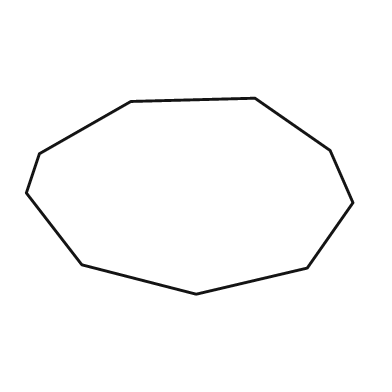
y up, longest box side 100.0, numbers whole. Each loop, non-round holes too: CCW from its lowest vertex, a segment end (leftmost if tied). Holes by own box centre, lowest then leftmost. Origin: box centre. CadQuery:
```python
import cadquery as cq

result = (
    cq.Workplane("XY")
    .moveTo(2.0, -30.0)
    .lineTo(36.0, -22.0)
    .lineTo(50.0, -2.0)
    .lineTo(43.0, 14.0)
    .lineTo(20.0, 30.0)
    .lineTo(-18.0, 29.0)
    .lineTo(-46.0, 13.0)
    .lineTo(-50.0, 1.0)
    .lineTo(-33.0, -21.0)
    .close()
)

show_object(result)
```